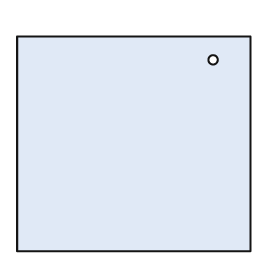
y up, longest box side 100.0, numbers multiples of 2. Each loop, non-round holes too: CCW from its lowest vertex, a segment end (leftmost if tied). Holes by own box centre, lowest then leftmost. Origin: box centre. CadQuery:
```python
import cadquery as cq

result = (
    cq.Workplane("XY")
    .moveTo(-50.0, -46.0)
    .lineTo(50.0, -46.0)
    .lineTo(50.0, 46.0)
    .lineTo(-50.0, 46.0)
    .close()
    .moveTo(34.0, 36.0)
    .circle(2.0)
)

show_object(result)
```